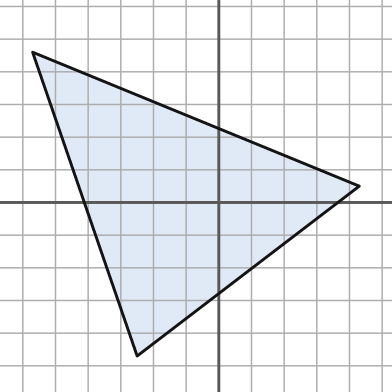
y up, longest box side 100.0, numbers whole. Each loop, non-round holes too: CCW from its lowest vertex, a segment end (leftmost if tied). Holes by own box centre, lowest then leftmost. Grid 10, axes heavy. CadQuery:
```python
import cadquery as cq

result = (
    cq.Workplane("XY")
    .moveTo(-25.0, -47.0)
    .lineTo(43.0, 5.0)
    .lineTo(-57.0, 46.0)
    .close()
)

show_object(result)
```